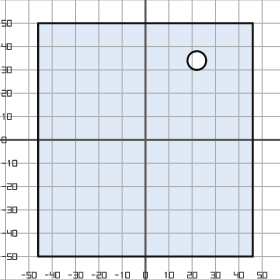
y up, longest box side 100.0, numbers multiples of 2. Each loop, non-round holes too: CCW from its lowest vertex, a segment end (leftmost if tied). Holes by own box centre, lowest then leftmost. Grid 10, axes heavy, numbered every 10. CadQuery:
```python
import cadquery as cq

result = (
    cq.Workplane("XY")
    .moveTo(-46.0, -50.0)
    .lineTo(46.0, -50.0)
    .lineTo(46.0, 50.0)
    .lineTo(-46.0, 50.0)
    .close()
    .moveTo(22.0, 34.0)
    .circle(4.0)
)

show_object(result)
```